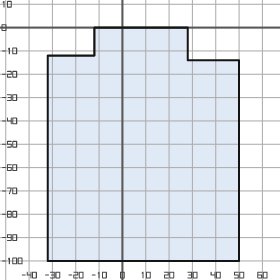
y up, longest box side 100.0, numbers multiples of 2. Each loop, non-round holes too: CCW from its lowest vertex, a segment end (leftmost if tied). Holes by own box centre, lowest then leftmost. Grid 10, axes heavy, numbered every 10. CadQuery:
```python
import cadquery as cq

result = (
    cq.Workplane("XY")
    .moveTo(-32.0, -100.0)
    .lineTo(50.0, -100.0)
    .lineTo(50.0, -14.0)
    .lineTo(28.0, -14.0)
    .lineTo(28.0, 0.0)
    .lineTo(-12.0, 0.0)
    .lineTo(-12.0, -12.0)
    .lineTo(-32.0, -12.0)
    .close()
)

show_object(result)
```